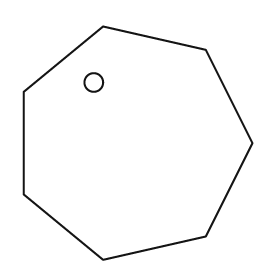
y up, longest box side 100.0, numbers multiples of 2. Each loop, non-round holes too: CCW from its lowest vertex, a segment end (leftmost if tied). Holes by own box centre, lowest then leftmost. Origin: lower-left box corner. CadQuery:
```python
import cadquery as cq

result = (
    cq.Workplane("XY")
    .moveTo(34.0, 0.0)
    .lineTo(78.0, 10.0)
    .lineTo(98.0, 50.0)
    .lineTo(78.0, 90.0)
    .lineTo(34.0, 100.0)
    .lineTo(0.0, 72.0)
    .lineTo(0.0, 28.0)
    .close()
    .moveTo(30.0, 76.0)
    .circle(4.0)
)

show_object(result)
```